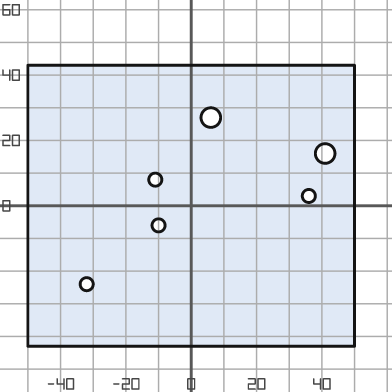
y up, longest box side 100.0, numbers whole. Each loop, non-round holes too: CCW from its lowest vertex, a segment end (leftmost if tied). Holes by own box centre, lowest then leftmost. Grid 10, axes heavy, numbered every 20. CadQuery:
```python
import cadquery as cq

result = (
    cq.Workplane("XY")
    .moveTo(-50.0, -43.0)
    .lineTo(50.0, -43.0)
    .lineTo(50.0, 43.0)
    .lineTo(-50.0, 43.0)
    .close()
    .moveTo(-32.0, -24.0)
    .circle(2.0)
    .moveTo(-10.0, -6.0)
    .circle(2.0)
    .moveTo(36.0, 3.0)
    .circle(2.0)
    .moveTo(-11.0, 8.0)
    .circle(2.0)
    .moveTo(41.0, 16.0)
    .circle(3.0)
    .moveTo(6.0, 27.0)
    .circle(3.0)
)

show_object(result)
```